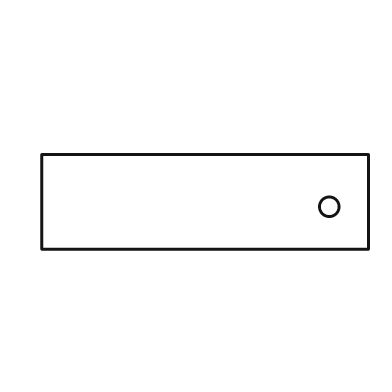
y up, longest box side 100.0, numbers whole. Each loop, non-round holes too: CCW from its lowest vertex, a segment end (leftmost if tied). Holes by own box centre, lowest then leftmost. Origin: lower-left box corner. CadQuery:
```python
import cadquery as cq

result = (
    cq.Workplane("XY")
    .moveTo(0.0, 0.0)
    .lineTo(100.0, 0.0)
    .lineTo(100.0, 29.0)
    .lineTo(0.0, 29.0)
    .close()
    .moveTo(88.0, 13.0)
    .circle(3.0)
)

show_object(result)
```